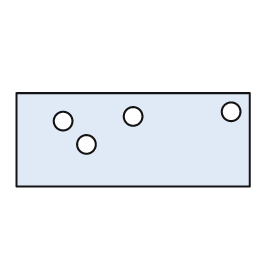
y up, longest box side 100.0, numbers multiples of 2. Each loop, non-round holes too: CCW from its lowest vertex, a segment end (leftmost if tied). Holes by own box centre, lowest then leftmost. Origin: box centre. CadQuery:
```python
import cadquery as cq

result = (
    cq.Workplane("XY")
    .moveTo(-50.0, -20.0)
    .lineTo(50.0, -20.0)
    .lineTo(50.0, 20.0)
    .lineTo(-50.0, 20.0)
    .close()
    .moveTo(-20.0, -2.0)
    .circle(4.0)
    .moveTo(-30.0, 8.0)
    .circle(4.0)
    .moveTo(0.0, 10.0)
    .circle(4.0)
    .moveTo(42.0, 12.0)
    .circle(4.0)
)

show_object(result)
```